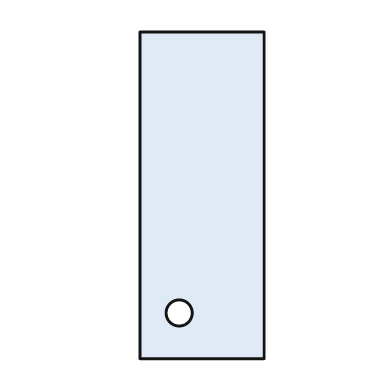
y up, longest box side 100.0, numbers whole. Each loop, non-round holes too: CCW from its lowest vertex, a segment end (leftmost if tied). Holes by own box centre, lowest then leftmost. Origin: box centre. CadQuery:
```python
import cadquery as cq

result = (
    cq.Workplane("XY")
    .moveTo(-19.0, -50.0)
    .lineTo(19.0, -50.0)
    .lineTo(19.0, 50.0)
    .lineTo(-19.0, 50.0)
    .close()
    .moveTo(-7.0, -36.0)
    .circle(4.0)
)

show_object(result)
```